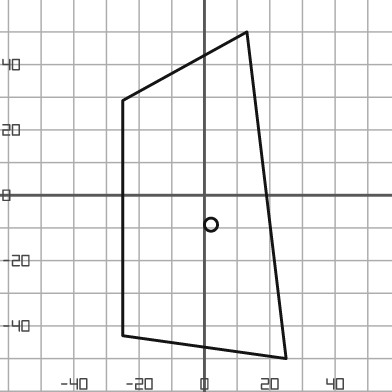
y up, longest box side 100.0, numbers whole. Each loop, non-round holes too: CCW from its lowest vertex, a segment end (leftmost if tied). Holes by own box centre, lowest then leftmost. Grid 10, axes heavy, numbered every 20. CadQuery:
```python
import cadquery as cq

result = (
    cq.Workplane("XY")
    .moveTo(25.0, -50.0)
    .lineTo(13.0, 50.0)
    .lineTo(-25.0, 29.0)
    .lineTo(-25.0, -43.0)
    .close()
    .moveTo(2.0, -9.0)
    .circle(2.0)
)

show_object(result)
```